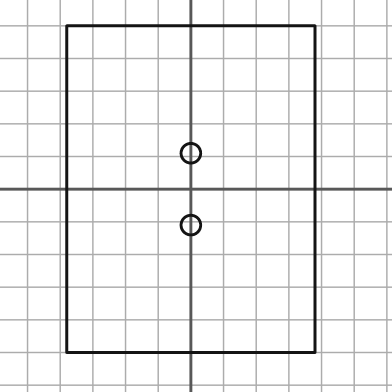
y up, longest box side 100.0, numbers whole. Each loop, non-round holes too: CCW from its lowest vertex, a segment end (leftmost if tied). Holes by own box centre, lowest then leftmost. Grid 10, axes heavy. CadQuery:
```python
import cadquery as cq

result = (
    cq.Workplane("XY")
    .moveTo(-38.0, -50.0)
    .lineTo(38.0, -50.0)
    .lineTo(38.0, 50.0)
    .lineTo(-38.0, 50.0)
    .close()
    .moveTo(0.0, -11.0)
    .circle(3.0)
    .moveTo(0.0, 11.0)
    .circle(3.0)
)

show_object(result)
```